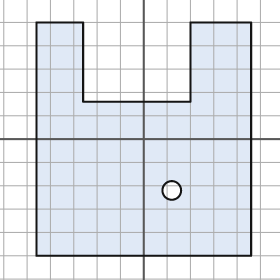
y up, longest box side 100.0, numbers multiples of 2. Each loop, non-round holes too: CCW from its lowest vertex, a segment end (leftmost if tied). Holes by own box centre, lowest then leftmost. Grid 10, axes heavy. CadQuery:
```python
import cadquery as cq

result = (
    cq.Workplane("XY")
    .moveTo(-46.0, -50.0)
    .lineTo(46.0, -50.0)
    .lineTo(46.0, 50.0)
    .lineTo(20.0, 50.0)
    .lineTo(20.0, 16.0)
    .lineTo(-26.0, 16.0)
    .lineTo(-26.0, 50.0)
    .lineTo(-46.0, 50.0)
    .close()
    .moveTo(12.0, -22.0)
    .circle(4.0)
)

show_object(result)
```